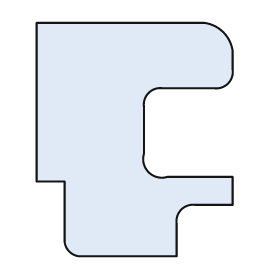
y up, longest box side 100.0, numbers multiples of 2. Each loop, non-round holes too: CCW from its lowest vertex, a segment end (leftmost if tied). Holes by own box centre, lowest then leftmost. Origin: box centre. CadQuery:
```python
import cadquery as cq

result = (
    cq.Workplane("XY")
    .moveTo(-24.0, -50.0)
    .lineTo(18.0, -50.0)
    .lineTo(18.0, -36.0)
    .threePointArc((20.0, -30.0), (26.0, -28.0))
    .lineTo(42.0, -28.0)
    .lineTo(42.0, -16.0)
    .lineTo(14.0, -16.0)
    .threePointArc((6.0, -14.0), (4.0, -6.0))
    .lineTo(4.0, 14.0)
    .threePointArc((6.0, 20.0), (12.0, 22.0))
    .lineTo(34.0, 22.0)
    .threePointArc((40.0, 24.0), (42.0, 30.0))
    .lineTo(42.0, 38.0)
    .threePointArc((38.0, 46.0), (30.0, 50.0))
    .lineTo(-42.0, 50.0)
    .lineTo(-42.0, -18.0)
    .lineTo(-30.0, -18.0)
    .lineTo(-30.0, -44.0)
    .threePointArc((-28.0, -48.0), (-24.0, -50.0))
    .close()
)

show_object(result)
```